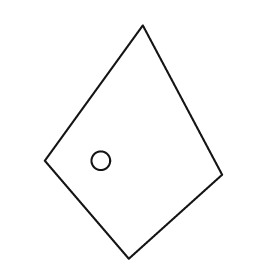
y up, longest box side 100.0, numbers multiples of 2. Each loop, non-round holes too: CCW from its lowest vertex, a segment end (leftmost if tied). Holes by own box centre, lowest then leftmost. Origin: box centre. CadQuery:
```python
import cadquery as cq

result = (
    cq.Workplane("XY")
    .moveTo(-2.0, -50.0)
    .lineTo(38.0, -14.0)
    .lineTo(4.0, 50.0)
    .lineTo(-38.0, -8.0)
    .close()
    .moveTo(-14.0, -8.0)
    .circle(4.0)
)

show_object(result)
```